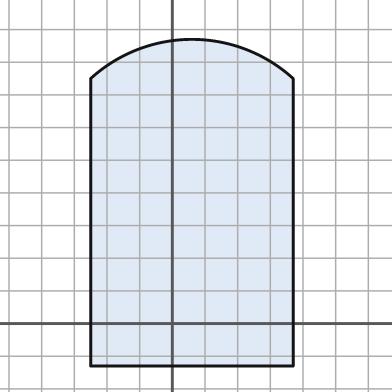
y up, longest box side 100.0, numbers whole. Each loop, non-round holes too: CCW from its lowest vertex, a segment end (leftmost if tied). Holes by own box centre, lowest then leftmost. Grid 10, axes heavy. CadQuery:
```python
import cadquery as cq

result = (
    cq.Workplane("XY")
    .moveTo(-25.0, -13.0)
    .lineTo(37.0, -13.0)
    .lineTo(37.0, 75.0)
    .threePointArc((6.0, 87.0), (-25.0, 75.0))
    .close()
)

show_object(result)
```